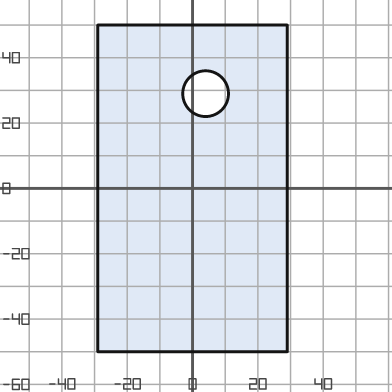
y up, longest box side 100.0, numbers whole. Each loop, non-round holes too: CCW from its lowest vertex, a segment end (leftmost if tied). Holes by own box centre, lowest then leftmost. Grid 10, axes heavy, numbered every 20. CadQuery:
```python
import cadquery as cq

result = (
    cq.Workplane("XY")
    .moveTo(-29.0, -50.0)
    .lineTo(29.0, -50.0)
    .lineTo(29.0, 50.0)
    .lineTo(-29.0, 50.0)
    .close()
    .moveTo(4.0, 29.0)
    .circle(7.0)
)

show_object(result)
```